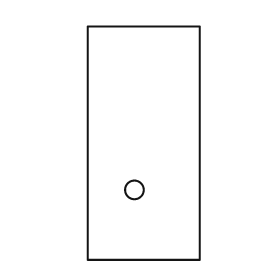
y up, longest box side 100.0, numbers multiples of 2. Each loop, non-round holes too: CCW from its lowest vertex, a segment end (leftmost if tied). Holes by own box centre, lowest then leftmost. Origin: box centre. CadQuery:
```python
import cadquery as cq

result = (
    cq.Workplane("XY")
    .moveTo(-24.0, -50.0)
    .lineTo(24.0, -50.0)
    .lineTo(24.0, 50.0)
    .lineTo(-24.0, 50.0)
    .close()
    .moveTo(-4.0, -20.0)
    .circle(4.0)
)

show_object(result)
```